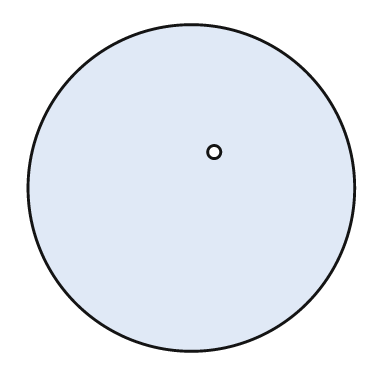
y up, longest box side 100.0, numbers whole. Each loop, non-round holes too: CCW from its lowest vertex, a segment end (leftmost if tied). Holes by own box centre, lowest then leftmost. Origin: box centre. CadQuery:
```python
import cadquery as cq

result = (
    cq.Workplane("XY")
    .moveTo(0.0, 0.0)
    .circle(50.0)
    .moveTo(7.0, 11.0)
    .circle(2.0)
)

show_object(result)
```